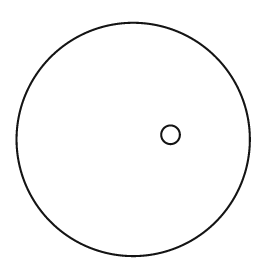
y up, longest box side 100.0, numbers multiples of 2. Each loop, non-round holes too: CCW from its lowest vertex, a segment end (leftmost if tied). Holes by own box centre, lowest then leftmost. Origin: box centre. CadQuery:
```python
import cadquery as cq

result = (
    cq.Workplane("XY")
    .moveTo(0.0, 0.0)
    .circle(50.0)
    .moveTo(16.0, 2.0)
    .circle(4.0)
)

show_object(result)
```